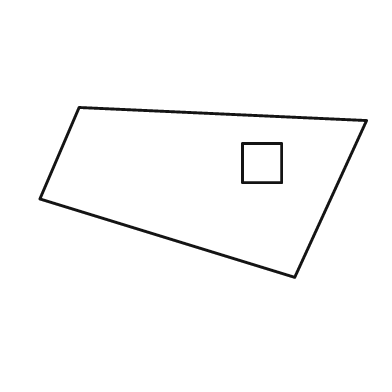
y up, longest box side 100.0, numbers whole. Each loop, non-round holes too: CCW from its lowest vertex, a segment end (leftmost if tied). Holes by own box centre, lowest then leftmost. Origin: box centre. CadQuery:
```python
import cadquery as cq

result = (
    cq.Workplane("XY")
    .moveTo(28.0, -26.0)
    .lineTo(50.0, 22.0)
    .lineTo(-38.0, 26.0)
    .lineTo(-50.0, -2.0)
    .close()
    .moveTo(12.0, 3.0)
    .lineTo(24.0, 3.0)
    .lineTo(24.0, 15.0)
    .lineTo(12.0, 15.0)
    .close()
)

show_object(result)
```